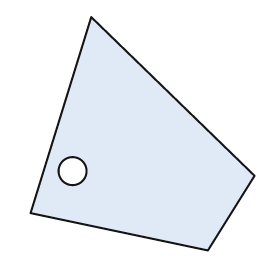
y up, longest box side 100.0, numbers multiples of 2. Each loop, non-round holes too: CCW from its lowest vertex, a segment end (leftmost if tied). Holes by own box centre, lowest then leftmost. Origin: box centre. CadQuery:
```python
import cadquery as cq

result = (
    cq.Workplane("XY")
    .moveTo(28.0, -50.0)
    .lineTo(48.0, -18.0)
    .lineTo(-22.0, 50.0)
    .lineTo(-48.0, -34.0)
    .close()
    .moveTo(-30.0, -16.0)
    .circle(6.0)
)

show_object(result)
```